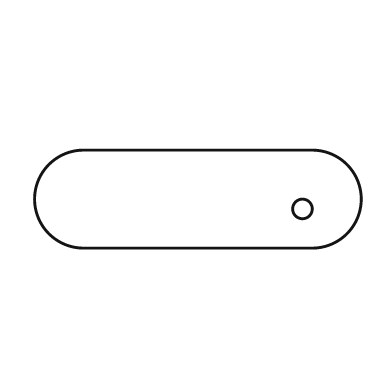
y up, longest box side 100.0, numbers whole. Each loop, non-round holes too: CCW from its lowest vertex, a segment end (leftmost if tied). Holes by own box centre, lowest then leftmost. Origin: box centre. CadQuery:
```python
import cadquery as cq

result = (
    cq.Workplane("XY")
    .moveTo(-35.0, -15.0)
    .lineTo(35.0, -15.0)
    .threePointArc((50.0, 0.0), (35.0, 15.0))
    .lineTo(-35.0, 15.0)
    .threePointArc((-50.0, 0.0), (-35.0, -15.0))
    .close()
    .moveTo(32.0, -3.0)
    .circle(3.0)
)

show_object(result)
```